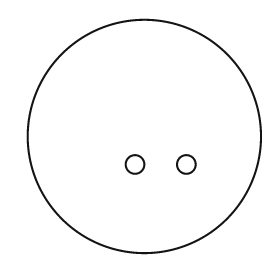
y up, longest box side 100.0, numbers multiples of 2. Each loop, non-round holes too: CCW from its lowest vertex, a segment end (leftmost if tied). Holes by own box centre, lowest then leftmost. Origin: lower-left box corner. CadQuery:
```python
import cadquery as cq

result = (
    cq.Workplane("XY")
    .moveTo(50.0, 50.0)
    .circle(50.0)
    .moveTo(46.0, 38.0)
    .circle(4.0)
    .moveTo(68.0, 38.0)
    .circle(4.0)
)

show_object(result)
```